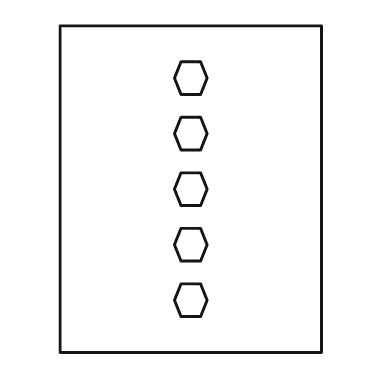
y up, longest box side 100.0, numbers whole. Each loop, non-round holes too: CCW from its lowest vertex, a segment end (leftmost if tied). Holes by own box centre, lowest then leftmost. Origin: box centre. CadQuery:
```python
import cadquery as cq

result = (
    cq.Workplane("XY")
    .moveTo(-40.0, -50.0)
    .lineTo(40.0, -50.0)
    .lineTo(40.0, 50.0)
    .lineTo(-40.0, 50.0)
    .close()
    .moveTo(-3.0, -39.0)
    .lineTo(3.0, -39.0)
    .lineTo(5.0, -34.0)
    .lineTo(3.0, -29.0)
    .lineTo(-3.0, -29.0)
    .lineTo(-5.0, -34.0)
    .close()
    .moveTo(-3.0, -22.0)
    .lineTo(3.0, -22.0)
    .lineTo(5.0, -17.0)
    .lineTo(3.0, -12.0)
    .lineTo(-3.0, -12.0)
    .lineTo(-5.0, -17.0)
    .close()
    .moveTo(-3.0, -5.0)
    .lineTo(3.0, -5.0)
    .lineTo(5.0, 0.0)
    .lineTo(3.0, 5.0)
    .lineTo(-3.0, 5.0)
    .lineTo(-5.0, 0.0)
    .close()
    .moveTo(-3.0, 12.0)
    .lineTo(3.0, 12.0)
    .lineTo(5.0, 17.0)
    .lineTo(3.0, 22.0)
    .lineTo(-3.0, 22.0)
    .lineTo(-5.0, 17.0)
    .close()
    .moveTo(-3.0, 29.0)
    .lineTo(3.0, 29.0)
    .lineTo(5.0, 34.0)
    .lineTo(3.0, 39.0)
    .lineTo(-3.0, 39.0)
    .lineTo(-5.0, 34.0)
    .close()
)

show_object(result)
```